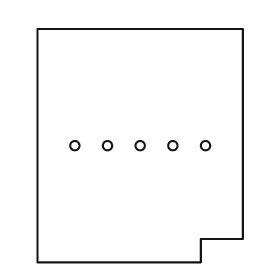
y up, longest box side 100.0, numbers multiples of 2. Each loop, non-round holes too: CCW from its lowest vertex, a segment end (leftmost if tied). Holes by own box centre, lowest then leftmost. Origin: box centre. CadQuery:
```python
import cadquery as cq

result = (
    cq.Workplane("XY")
    .moveTo(-44.0, -50.0)
    .lineTo(26.0, -50.0)
    .lineTo(26.0, -40.0)
    .lineTo(44.0, -40.0)
    .lineTo(44.0, 50.0)
    .lineTo(-44.0, 50.0)
    .close()
    .moveTo(-28.0, 0.0)
    .circle(2.0)
    .moveTo(-14.0, 0.0)
    .circle(2.0)
    .moveTo(0.0, 0.0)
    .circle(2.0)
    .moveTo(14.0, 0.0)
    .circle(2.0)
    .moveTo(28.0, 0.0)
    .circle(2.0)
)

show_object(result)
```